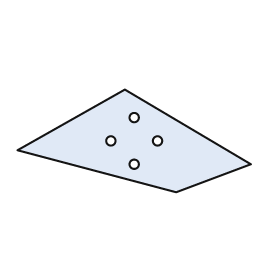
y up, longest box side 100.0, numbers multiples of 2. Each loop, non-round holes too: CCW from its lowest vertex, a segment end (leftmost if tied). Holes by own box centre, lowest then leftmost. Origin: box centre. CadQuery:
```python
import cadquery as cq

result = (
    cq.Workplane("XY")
    .moveTo(18.0, -22.0)
    .lineTo(50.0, -10.0)
    .lineTo(-4.0, 22.0)
    .lineTo(-50.0, -4.0)
    .close()
    .moveTo(0.0, -10.0)
    .circle(2.0)
    .moveTo(-10.0, 0.0)
    .circle(2.0)
    .moveTo(10.0, 0.0)
    .circle(2.0)
    .moveTo(0.0, 10.0)
    .circle(2.0)
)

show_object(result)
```